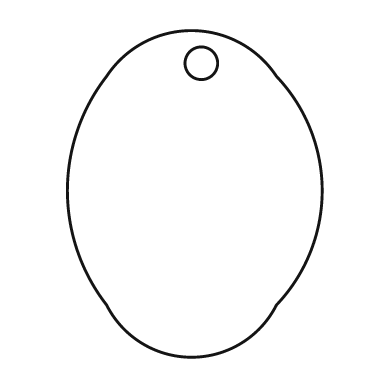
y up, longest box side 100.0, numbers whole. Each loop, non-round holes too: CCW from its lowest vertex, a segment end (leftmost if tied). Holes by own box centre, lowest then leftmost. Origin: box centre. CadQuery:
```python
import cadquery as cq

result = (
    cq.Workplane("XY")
    .moveTo(-27.0, -34.0)
    .threePointArc((-1.0, -50.0), (25.0, -34.0))
    .threePointArc((39.0, 1.0), (25.0, 36.0))
    .threePointArc((-1.0, 50.0), (-27.0, 36.0))
    .threePointArc((-39.0, 1.0), (-27.0, -34.0))
    .close()
    .moveTo(2.0, 40.0)
    .circle(5.0)
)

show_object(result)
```